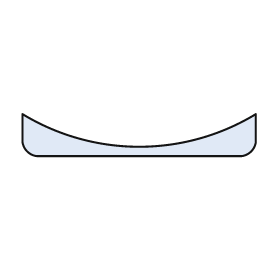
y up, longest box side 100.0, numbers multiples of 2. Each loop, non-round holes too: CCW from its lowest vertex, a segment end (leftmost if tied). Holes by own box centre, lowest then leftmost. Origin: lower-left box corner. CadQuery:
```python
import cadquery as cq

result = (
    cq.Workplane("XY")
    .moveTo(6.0, 0.0)
    .lineTo(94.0, 0.0)
    .threePointArc((98.0, 2.0), (100.0, 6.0))
    .lineTo(100.0, 18.0)
    .threePointArc((50.0, 4.0), (0.0, 18.0))
    .lineTo(0.0, 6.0)
    .threePointArc((2.0, 2.0), (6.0, 0.0))
    .close()
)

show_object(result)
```